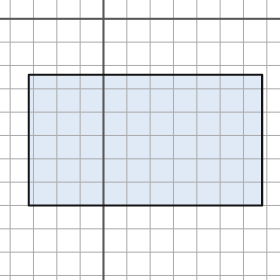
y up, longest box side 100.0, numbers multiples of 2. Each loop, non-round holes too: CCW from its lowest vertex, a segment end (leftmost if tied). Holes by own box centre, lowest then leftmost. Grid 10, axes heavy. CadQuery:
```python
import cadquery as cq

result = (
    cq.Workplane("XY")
    .moveTo(-32.0, -80.0)
    .lineTo(68.0, -80.0)
    .lineTo(68.0, -24.0)
    .lineTo(-32.0, -24.0)
    .close()
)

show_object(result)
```